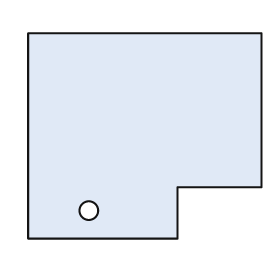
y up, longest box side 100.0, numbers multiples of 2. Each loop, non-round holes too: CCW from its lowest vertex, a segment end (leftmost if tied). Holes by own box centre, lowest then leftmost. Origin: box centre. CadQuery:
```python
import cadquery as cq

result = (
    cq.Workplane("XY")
    .moveTo(-50.0, -44.0)
    .lineTo(14.0, -44.0)
    .lineTo(14.0, -22.0)
    .lineTo(50.0, -22.0)
    .lineTo(50.0, 44.0)
    .lineTo(-50.0, 44.0)
    .close()
    .moveTo(-24.0, -32.0)
    .circle(4.0)
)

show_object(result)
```